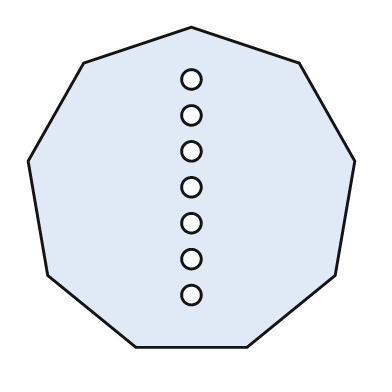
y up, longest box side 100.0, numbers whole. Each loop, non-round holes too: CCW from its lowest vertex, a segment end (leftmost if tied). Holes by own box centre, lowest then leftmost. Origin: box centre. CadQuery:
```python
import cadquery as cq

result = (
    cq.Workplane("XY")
    .moveTo(-17.0, -49.0)
    .lineTo(17.0, -49.0)
    .lineTo(44.0, -27.0)
    .lineTo(50.0, 8.0)
    .lineTo(33.0, 38.0)
    .lineTo(0.0, 49.0)
    .lineTo(-33.0, 38.0)
    .lineTo(-50.0, 8.0)
    .lineTo(-44.0, -27.0)
    .close()
    .moveTo(0.0, -33.0)
    .circle(3.0)
    .moveTo(0.0, -22.0)
    .circle(3.0)
    .moveTo(0.0, -11.0)
    .circle(3.0)
    .moveTo(0.0, 0.0)
    .circle(3.0)
    .moveTo(0.0, 11.0)
    .circle(3.0)
    .moveTo(0.0, 22.0)
    .circle(3.0)
    .moveTo(0.0, 33.0)
    .circle(3.0)
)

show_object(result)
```